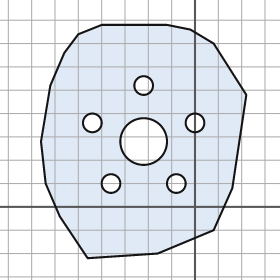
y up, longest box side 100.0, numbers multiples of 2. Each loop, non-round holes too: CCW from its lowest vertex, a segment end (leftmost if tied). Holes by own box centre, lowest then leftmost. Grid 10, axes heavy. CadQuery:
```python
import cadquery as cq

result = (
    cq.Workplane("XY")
    .moveTo(-46.0, -22.0)
    .lineTo(-16.0, -20.0)
    .lineTo(8.0, -10.0)
    .lineTo(16.0, 8.0)
    .lineTo(22.0, 48.0)
    .lineTo(8.0, 70.0)
    .lineTo(-2.0, 76.0)
    .lineTo(-12.0, 78.0)
    .lineTo(-40.0, 78.0)
    .lineTo(-50.0, 74.0)
    .lineTo(-56.0, 66.0)
    .lineTo(-62.0, 52.0)
    .lineTo(-66.0, 28.0)
    .lineTo(-64.0, 10.0)
    .lineTo(-58.0, -4.0)
    .close()
    .moveTo(-36.0, 10.0)
    .circle(4.0)
    .moveTo(-8.0, 10.0)
    .circle(4.0)
    .moveTo(-22.0, 28.0)
    .circle(10.0)
    .moveTo(-44.0, 36.0)
    .circle(4.0)
    .moveTo(0.0, 36.0)
    .circle(4.0)
    .moveTo(-22.0, 52.0)
    .circle(4.0)
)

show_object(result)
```